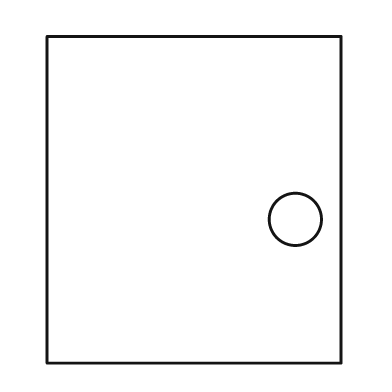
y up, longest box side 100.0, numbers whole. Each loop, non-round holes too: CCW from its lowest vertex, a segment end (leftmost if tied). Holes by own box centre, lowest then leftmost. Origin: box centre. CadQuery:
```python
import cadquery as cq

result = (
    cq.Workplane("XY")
    .moveTo(-45.0, -50.0)
    .lineTo(45.0, -50.0)
    .lineTo(45.0, 50.0)
    .lineTo(-45.0, 50.0)
    .close()
    .moveTo(31.0, -6.0)
    .circle(8.0)
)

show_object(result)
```